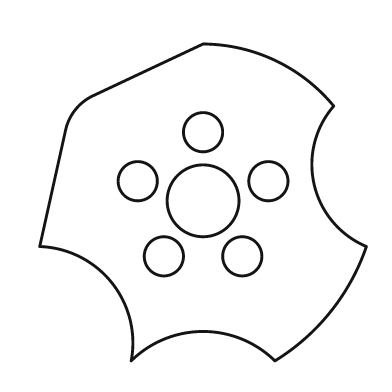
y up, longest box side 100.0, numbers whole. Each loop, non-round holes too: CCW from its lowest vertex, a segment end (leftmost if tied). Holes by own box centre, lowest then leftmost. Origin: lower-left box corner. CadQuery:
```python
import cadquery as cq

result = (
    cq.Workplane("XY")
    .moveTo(28.0, 0.0)
    .threePointArc((50.0, 9.0), (72.0, 0.0))
    .threePointArc((89.0, 15.0), (100.0, 35.0))
    .threePointArc((84.0, 54.0), (90.0, 78.0))
    .threePointArc((72.0, 92.0), (50.0, 97.0))
    .lineTo(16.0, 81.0)
    .threePointArc((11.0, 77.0), (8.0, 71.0))
    .lineTo(0.0, 35.0)
    .threePointArc((22.0, 24.0), (28.0, 0.0))
    .close()
    .moveTo(38.0, 32.0)
    .circle(6.0)
    .moveTo(62.0, 32.0)
    .circle(6.0)
    .moveTo(50.0, 49.0)
    .circle(11.0)
    .moveTo(30.0, 55.0)
    .circle(6.0)
    .moveTo(70.0, 55.0)
    .circle(6.0)
    .moveTo(50.0, 70.0)
    .circle(6.0)
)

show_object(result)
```